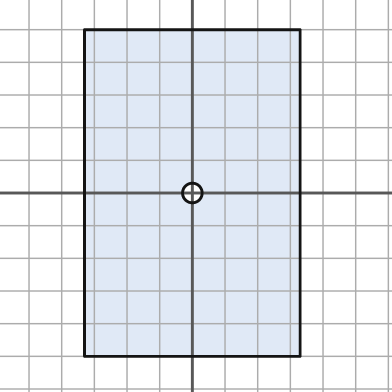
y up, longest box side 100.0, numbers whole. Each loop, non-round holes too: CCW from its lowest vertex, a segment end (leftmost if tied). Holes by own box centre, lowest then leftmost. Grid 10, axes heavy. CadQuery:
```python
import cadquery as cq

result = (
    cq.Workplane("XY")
    .moveTo(-33.0, -50.0)
    .lineTo(33.0, -50.0)
    .lineTo(33.0, 50.0)
    .lineTo(-33.0, 50.0)
    .close()
    .moveTo(0.0, 0.0)
    .circle(3.0)
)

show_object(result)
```